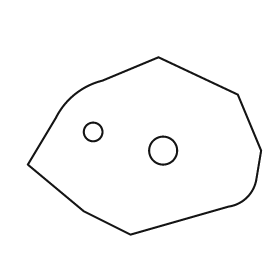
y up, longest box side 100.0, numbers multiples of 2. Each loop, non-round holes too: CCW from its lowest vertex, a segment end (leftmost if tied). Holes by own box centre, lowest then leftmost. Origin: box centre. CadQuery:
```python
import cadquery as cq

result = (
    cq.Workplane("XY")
    .moveTo(-6.0, -38.0)
    .lineTo(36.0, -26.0)
    .threePointArc((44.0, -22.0), (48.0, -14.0))
    .lineTo(50.0, -2.0)
    .lineTo(40.0, 22.0)
    .lineTo(6.0, 38.0)
    .lineTo(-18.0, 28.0)
    .threePointArc((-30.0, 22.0), (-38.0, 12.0))
    .lineTo(-50.0, -8.0)
    .lineTo(-26.0, -28.0)
    .close()
    .moveTo(8.0, -2.0)
    .circle(6.0)
    .moveTo(-22.0, 6.0)
    .circle(4.0)
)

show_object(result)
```